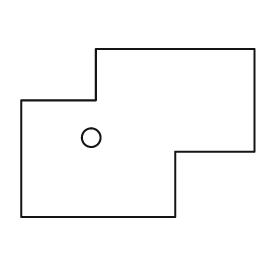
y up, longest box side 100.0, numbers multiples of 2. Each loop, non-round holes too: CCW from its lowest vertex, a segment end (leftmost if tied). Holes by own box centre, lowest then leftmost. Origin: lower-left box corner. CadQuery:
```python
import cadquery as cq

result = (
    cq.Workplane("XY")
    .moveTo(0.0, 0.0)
    .lineTo(66.0, 0.0)
    .lineTo(66.0, 28.0)
    .lineTo(100.0, 28.0)
    .lineTo(100.0, 72.0)
    .lineTo(32.0, 72.0)
    .lineTo(32.0, 50.0)
    .lineTo(0.0, 50.0)
    .close()
    .moveTo(30.0, 34.0)
    .circle(4.0)
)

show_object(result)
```